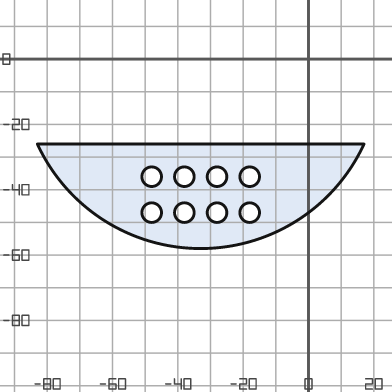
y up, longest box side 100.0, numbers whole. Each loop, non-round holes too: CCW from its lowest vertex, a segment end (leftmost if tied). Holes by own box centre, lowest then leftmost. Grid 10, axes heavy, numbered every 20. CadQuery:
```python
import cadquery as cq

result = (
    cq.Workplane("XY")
    .moveTo(-83.0, -26.0)
    .threePointArc((-33.0, -58.0), (17.0, -26.0))
    .close()
    .moveTo(-48.0, -47.0)
    .circle(3.0)
    .moveTo(-38.0, -47.0)
    .circle(3.0)
    .moveTo(-28.0, -47.0)
    .circle(3.0)
    .moveTo(-18.0, -47.0)
    .circle(3.0)
    .moveTo(-48.0, -36.0)
    .circle(3.0)
    .moveTo(-38.0, -36.0)
    .circle(3.0)
    .moveTo(-28.0, -36.0)
    .circle(3.0)
    .moveTo(-18.0, -36.0)
    .circle(3.0)
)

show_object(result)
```